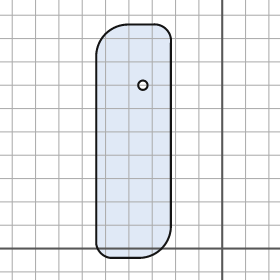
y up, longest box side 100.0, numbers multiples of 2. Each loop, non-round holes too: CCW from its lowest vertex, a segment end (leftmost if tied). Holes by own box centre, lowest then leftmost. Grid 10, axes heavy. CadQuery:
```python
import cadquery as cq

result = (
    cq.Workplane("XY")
    .moveTo(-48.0, -4.0)
    .lineTo(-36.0, -4.0)
    .threePointArc((-26.0, 0.0), (-22.0, 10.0))
    .lineTo(-22.0, 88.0)
    .threePointArc((-24.0, 94.0), (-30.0, 96.0))
    .lineTo(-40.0, 96.0)
    .threePointArc((-50.0, 92.0), (-54.0, 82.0))
    .lineTo(-54.0, 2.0)
    .threePointArc((-52.0, -2.0), (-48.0, -4.0))
    .close()
    .moveTo(-34.0, 70.0)
    .circle(2.0)
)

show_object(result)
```